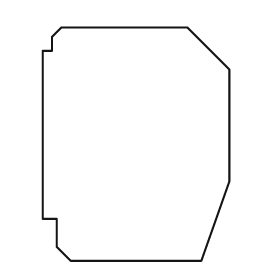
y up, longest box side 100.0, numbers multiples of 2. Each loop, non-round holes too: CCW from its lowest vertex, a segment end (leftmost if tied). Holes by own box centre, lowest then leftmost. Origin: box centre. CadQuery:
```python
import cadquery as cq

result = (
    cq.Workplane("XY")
    .moveTo(-28.0, -50.0)
    .lineTo(28.0, -50.0)
    .lineTo(40.0, -16.0)
    .lineTo(40.0, 32.0)
    .lineTo(22.0, 50.0)
    .lineTo(-32.0, 50.0)
    .lineTo(-36.0, 46.0)
    .lineTo(-36.0, 40.0)
    .lineTo(-40.0, 40.0)
    .lineTo(-40.0, -32.0)
    .lineTo(-34.0, -32.0)
    .lineTo(-34.0, -44.0)
    .close()
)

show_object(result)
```